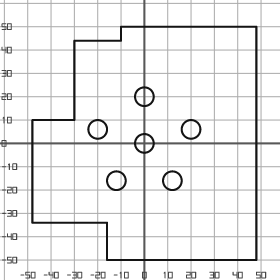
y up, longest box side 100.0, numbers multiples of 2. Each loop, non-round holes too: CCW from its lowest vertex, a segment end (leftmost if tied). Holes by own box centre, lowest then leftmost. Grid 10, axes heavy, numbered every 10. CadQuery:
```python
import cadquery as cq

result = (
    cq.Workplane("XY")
    .moveTo(-16.0, -50.0)
    .lineTo(48.0, -50.0)
    .lineTo(48.0, 50.0)
    .lineTo(-10.0, 50.0)
    .lineTo(-10.0, 44.0)
    .lineTo(-30.0, 44.0)
    .lineTo(-30.0, 10.0)
    .lineTo(-48.0, 10.0)
    .lineTo(-48.0, -34.0)
    .lineTo(-16.0, -34.0)
    .close()
    .moveTo(-12.0, -16.0)
    .circle(4.0)
    .moveTo(12.0, -16.0)
    .circle(4.0)
    .moveTo(0.0, 0.0)
    .circle(4.0)
    .moveTo(-20.0, 6.0)
    .circle(4.0)
    .moveTo(20.0, 6.0)
    .circle(4.0)
    .moveTo(0.0, 20.0)
    .circle(4.0)
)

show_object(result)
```